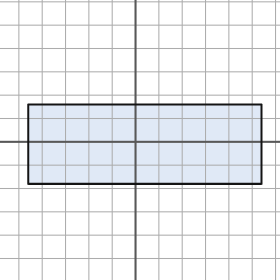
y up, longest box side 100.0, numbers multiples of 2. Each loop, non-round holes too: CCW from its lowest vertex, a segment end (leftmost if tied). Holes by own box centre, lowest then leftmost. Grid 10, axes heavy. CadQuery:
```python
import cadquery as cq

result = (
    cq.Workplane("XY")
    .moveTo(-46.0, -18.0)
    .lineTo(54.0, -18.0)
    .lineTo(54.0, 16.0)
    .lineTo(-46.0, 16.0)
    .close()
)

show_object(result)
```